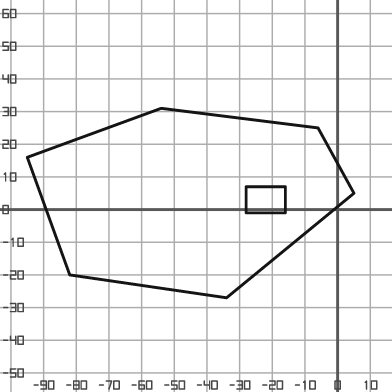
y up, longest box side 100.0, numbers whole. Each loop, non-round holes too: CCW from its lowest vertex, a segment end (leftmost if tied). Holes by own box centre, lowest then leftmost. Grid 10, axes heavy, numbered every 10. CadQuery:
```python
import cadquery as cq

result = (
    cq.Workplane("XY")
    .moveTo(-34.0, -27.0)
    .lineTo(5.0, 5.0)
    .lineTo(-6.0, 25.0)
    .lineTo(-54.0, 31.0)
    .lineTo(-95.0, 16.0)
    .lineTo(-82.0, -20.0)
    .close()
    .moveTo(-28.0, -1.0)
    .lineTo(-16.0, -1.0)
    .lineTo(-16.0, 7.0)
    .lineTo(-28.0, 7.0)
    .close()
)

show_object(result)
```